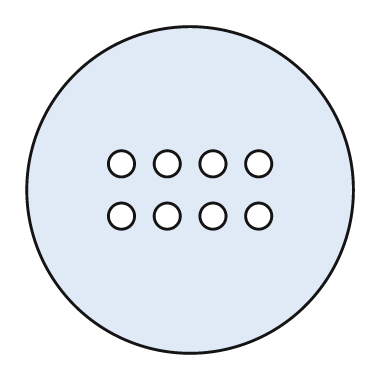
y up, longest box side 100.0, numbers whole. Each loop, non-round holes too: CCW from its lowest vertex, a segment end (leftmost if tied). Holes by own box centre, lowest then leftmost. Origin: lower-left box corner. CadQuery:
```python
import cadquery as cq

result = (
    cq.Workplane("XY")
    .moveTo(50.0, 50.0)
    .circle(50.0)
    .moveTo(29.0, 42.0)
    .circle(4.0)
    .moveTo(43.0, 42.0)
    .circle(4.0)
    .moveTo(57.0, 42.0)
    .circle(4.0)
    .moveTo(71.0, 42.0)
    .circle(4.0)
    .moveTo(29.0, 58.0)
    .circle(4.0)
    .moveTo(43.0, 58.0)
    .circle(4.0)
    .moveTo(57.0, 58.0)
    .circle(4.0)
    .moveTo(71.0, 58.0)
    .circle(4.0)
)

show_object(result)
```